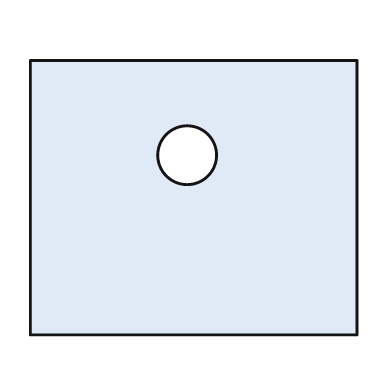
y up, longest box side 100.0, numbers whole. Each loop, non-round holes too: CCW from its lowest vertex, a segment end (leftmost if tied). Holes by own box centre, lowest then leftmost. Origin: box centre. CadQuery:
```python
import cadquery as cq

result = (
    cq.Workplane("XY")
    .moveTo(-50.0, -42.0)
    .lineTo(50.0, -42.0)
    .lineTo(50.0, 42.0)
    .lineTo(-50.0, 42.0)
    .close()
    .moveTo(-2.0, 13.0)
    .circle(9.0)
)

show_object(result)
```